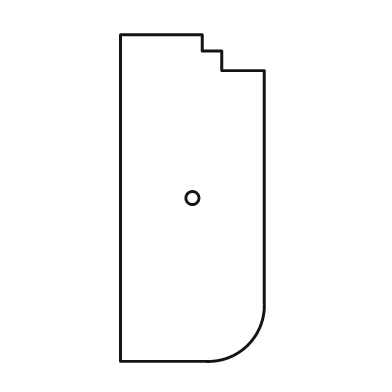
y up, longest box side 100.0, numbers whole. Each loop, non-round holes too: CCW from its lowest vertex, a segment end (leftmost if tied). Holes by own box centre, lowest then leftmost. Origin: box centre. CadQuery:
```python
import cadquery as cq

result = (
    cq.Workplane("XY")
    .moveTo(-22.0, -50.0)
    .lineTo(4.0, -50.0)
    .threePointArc((17.0, -45.0), (22.0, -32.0))
    .lineTo(22.0, 39.0)
    .lineTo(9.0, 39.0)
    .lineTo(9.0, 45.0)
    .lineTo(3.0, 45.0)
    .lineTo(3.0, 50.0)
    .lineTo(-22.0, 50.0)
    .close()
    .moveTo(0.0, 0.0)
    .circle(2.0)
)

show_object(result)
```